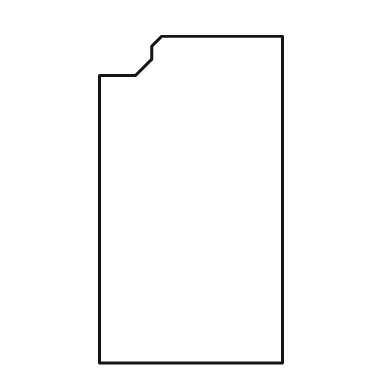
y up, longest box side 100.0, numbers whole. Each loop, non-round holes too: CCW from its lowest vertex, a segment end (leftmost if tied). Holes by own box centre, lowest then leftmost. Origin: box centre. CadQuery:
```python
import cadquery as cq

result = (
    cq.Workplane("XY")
    .moveTo(-28.0, -50.0)
    .lineTo(28.0, -50.0)
    .lineTo(28.0, 50.0)
    .lineTo(-9.0, 50.0)
    .lineTo(-12.0, 47.0)
    .lineTo(-12.0, 43.0)
    .lineTo(-17.0, 38.0)
    .lineTo(-28.0, 38.0)
    .close()
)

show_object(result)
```